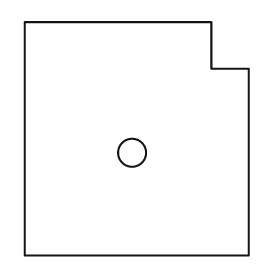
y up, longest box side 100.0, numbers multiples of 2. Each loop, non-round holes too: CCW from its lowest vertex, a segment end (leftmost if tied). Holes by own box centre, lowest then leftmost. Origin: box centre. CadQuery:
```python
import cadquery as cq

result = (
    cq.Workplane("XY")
    .moveTo(-48.0, -50.0)
    .lineTo(48.0, -50.0)
    .lineTo(48.0, 30.0)
    .lineTo(32.0, 30.0)
    .lineTo(32.0, 50.0)
    .lineTo(-48.0, 50.0)
    .close()
    .moveTo(-2.0, -6.0)
    .circle(6.0)
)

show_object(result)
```